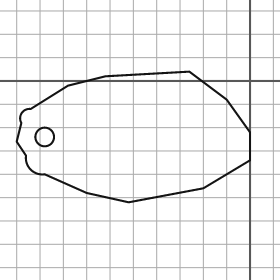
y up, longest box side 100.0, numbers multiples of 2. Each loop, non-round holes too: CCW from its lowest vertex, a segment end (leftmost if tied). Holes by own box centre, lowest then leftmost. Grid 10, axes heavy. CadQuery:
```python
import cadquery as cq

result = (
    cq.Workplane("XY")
    .moveTo(-52.0, -52.0)
    .lineTo(-20.0, -46.0)
    .lineTo(0.0, -34.0)
    .lineTo(0.0, -22.0)
    .lineTo(-10.0, -8.0)
    .lineTo(-26.0, 4.0)
    .lineTo(-62.0, 2.0)
    .lineTo(-78.0, -2.0)
    .lineTo(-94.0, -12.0)
    .threePointArc((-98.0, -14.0), (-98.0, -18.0))
    .lineTo(-100.0, -26.0)
    .lineTo(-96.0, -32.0)
    .threePointArc((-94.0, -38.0), (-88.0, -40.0))
    .lineTo(-70.0, -48.0)
    .close()
    .moveTo(-88.0, -24.0)
    .circle(4.0)
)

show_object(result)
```